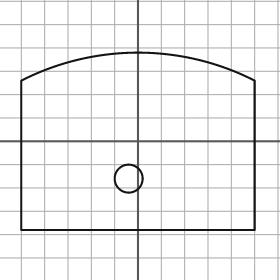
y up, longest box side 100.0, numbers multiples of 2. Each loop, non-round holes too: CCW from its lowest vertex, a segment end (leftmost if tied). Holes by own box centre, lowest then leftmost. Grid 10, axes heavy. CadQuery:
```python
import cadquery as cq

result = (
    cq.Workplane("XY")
    .moveTo(-50.0, -38.0)
    .lineTo(50.0, -38.0)
    .lineTo(50.0, 26.0)
    .threePointArc((0.0, 38.0), (-50.0, 26.0))
    .close()
    .moveTo(-4.0, -16.0)
    .circle(6.0)
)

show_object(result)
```